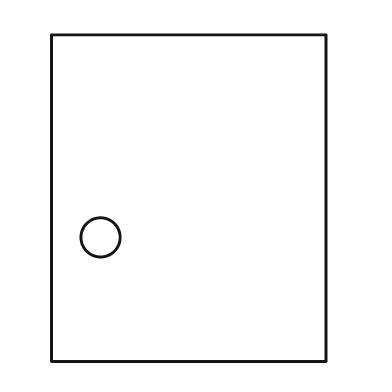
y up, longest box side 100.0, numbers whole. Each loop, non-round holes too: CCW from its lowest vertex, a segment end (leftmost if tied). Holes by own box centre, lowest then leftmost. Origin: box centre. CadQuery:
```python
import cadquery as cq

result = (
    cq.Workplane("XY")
    .moveTo(-42.0, -50.0)
    .lineTo(42.0, -50.0)
    .lineTo(42.0, 50.0)
    .lineTo(-42.0, 50.0)
    .close()
    .moveTo(-27.0, -12.0)
    .circle(6.0)
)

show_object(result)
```